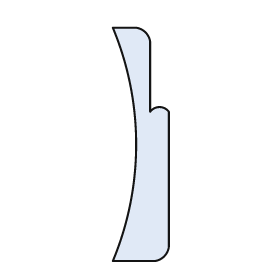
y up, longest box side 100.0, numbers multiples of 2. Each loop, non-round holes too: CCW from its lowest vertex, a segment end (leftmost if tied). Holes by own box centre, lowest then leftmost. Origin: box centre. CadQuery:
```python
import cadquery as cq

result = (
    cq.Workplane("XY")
    .moveTo(-12.0, -50.0)
    .lineTo(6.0, -50.0)
    .threePointArc((10.0, -48.0), (12.0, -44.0))
    .lineTo(12.0, 14.0)
    .threePointArc((8.0, 16.0), (4.0, 14.0))
    .lineTo(4.0, 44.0)
    .threePointArc((2.0, 48.0), (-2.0, 50.0))
    .lineTo(-12.0, 50.0)
    .threePointArc((-2.0, 0.0), (-12.0, -50.0))
    .close()
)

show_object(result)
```